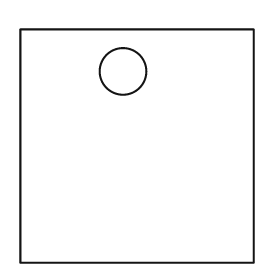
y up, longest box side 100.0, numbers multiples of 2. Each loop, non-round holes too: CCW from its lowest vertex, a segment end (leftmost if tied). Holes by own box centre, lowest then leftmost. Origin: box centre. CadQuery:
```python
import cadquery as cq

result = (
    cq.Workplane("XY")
    .moveTo(-50.0, -50.0)
    .lineTo(50.0, -50.0)
    .lineTo(50.0, 50.0)
    .lineTo(-50.0, 50.0)
    .close()
    .moveTo(-6.0, 32.0)
    .circle(10.0)
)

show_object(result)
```